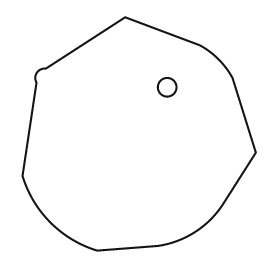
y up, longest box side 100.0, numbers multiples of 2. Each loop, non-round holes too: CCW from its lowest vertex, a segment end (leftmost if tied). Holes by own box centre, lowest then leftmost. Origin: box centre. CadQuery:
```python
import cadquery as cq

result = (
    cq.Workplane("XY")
    .moveTo(-18.0, -50.0)
    .lineTo(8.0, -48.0)
    .threePointArc((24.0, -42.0), (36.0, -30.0))
    .lineTo(50.0, -8.0)
    .lineTo(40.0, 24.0)
    .threePointArc((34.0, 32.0), (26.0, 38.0))
    .lineTo(-6.0, 50.0)
    .lineTo(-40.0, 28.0)
    .threePointArc((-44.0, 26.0), (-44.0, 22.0))
    .lineTo(-50.0, -18.0)
    .threePointArc((-38.0, -38.0), (-18.0, -50.0))
    .close()
    .moveTo(12.0, 20.0)
    .circle(4.0)
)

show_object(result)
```